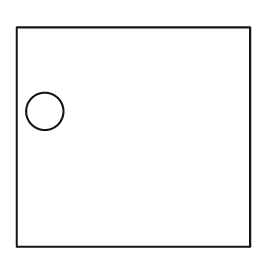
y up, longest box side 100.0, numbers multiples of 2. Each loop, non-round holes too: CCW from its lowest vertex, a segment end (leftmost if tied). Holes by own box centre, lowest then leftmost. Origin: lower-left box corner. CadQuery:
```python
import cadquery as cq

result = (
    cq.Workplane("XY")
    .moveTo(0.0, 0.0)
    .lineTo(100.0, 0.0)
    .lineTo(100.0, 94.0)
    .lineTo(0.0, 94.0)
    .close()
    .moveTo(12.0, 58.0)
    .circle(8.0)
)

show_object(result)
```